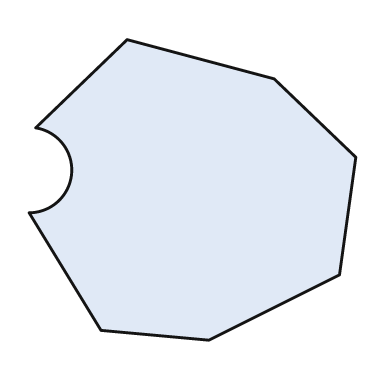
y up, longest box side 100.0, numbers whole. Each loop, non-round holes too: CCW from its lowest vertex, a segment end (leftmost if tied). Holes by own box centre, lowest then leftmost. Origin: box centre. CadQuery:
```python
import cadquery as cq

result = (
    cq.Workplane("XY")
    .moveTo(5.0, -46.0)
    .lineTo(45.0, -26.0)
    .lineTo(50.0, 10.0)
    .lineTo(25.0, 34.0)
    .lineTo(-20.0, 46.0)
    .lineTo(-48.0, 19.0)
    .threePointArc((-37.0, 5.0), (-50.0, -7.0))
    .lineTo(-28.0, -43.0)
    .close()
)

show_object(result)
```